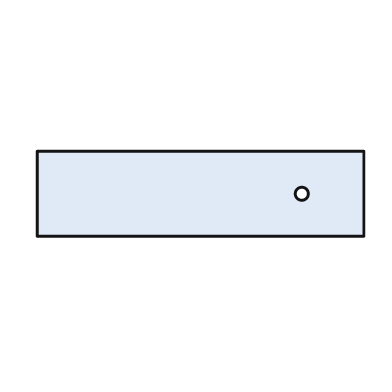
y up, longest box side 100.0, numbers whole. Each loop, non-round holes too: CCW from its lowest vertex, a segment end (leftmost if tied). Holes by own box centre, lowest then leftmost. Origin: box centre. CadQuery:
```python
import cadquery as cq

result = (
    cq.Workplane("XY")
    .moveTo(-50.0, -13.0)
    .lineTo(50.0, -13.0)
    .lineTo(50.0, 13.0)
    .lineTo(-50.0, 13.0)
    .close()
    .moveTo(31.0, 0.0)
    .circle(2.0)
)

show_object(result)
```